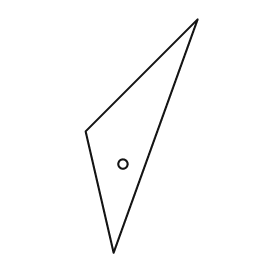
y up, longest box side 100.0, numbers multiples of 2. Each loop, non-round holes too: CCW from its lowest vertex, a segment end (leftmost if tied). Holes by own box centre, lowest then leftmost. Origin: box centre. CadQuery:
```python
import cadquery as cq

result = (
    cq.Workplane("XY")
    .moveTo(-12.0, -50.0)
    .lineTo(24.0, 50.0)
    .lineTo(-24.0, 2.0)
    .close()
    .moveTo(-8.0, -12.0)
    .circle(2.0)
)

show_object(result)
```